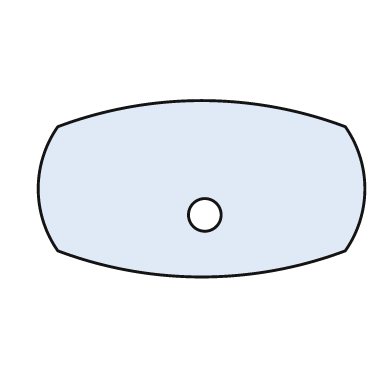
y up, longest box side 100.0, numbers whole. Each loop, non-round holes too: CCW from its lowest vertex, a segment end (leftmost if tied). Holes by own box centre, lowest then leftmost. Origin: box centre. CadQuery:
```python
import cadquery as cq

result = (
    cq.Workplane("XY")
    .moveTo(-44.0, -19.0)
    .threePointArc((0.0, -27.0), (44.0, -19.0))
    .threePointArc((50.0, 0.0), (44.0, 19.0))
    .threePointArc((0.0, 27.0), (-44.0, 19.0))
    .threePointArc((-50.0, 0.0), (-44.0, -19.0))
    .close()
    .moveTo(1.0, -8.0)
    .circle(5.0)
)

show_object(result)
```